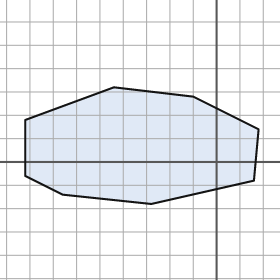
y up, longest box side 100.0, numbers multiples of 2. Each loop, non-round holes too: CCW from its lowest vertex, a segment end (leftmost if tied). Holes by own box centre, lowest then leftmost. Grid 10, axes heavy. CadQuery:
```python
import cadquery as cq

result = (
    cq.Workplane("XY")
    .moveTo(-28.0, -18.0)
    .lineTo(16.0, -8.0)
    .lineTo(18.0, 14.0)
    .lineTo(-10.0, 28.0)
    .lineTo(-44.0, 32.0)
    .lineTo(-82.0, 18.0)
    .lineTo(-82.0, -6.0)
    .lineTo(-66.0, -14.0)
    .close()
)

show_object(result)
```